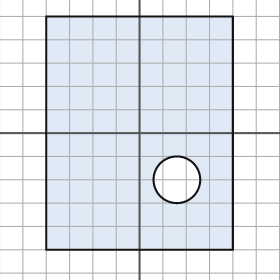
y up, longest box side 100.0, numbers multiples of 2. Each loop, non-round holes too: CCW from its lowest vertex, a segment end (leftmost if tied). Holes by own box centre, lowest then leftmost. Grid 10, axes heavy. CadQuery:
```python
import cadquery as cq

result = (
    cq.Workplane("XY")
    .moveTo(-40.0, -50.0)
    .lineTo(40.0, -50.0)
    .lineTo(40.0, 50.0)
    .lineTo(-40.0, 50.0)
    .close()
    .moveTo(16.0, -20.0)
    .circle(10.0)
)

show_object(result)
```